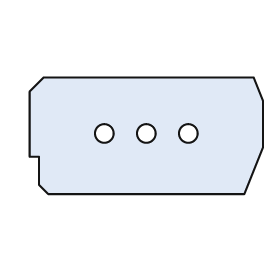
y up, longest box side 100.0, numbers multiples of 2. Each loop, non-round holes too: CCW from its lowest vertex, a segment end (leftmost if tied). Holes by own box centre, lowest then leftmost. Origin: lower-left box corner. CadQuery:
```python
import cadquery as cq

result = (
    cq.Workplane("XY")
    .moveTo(8.0, 0.0)
    .lineTo(92.0, 0.0)
    .lineTo(100.0, 20.0)
    .lineTo(100.0, 40.0)
    .lineTo(96.0, 50.0)
    .lineTo(6.0, 50.0)
    .lineTo(0.0, 44.0)
    .lineTo(0.0, 16.0)
    .lineTo(4.0, 16.0)
    .lineTo(4.0, 4.0)
    .close()
    .moveTo(32.0, 26.0)
    .circle(4.0)
    .moveTo(50.0, 26.0)
    .circle(4.0)
    .moveTo(68.0, 26.0)
    .circle(4.0)
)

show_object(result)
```